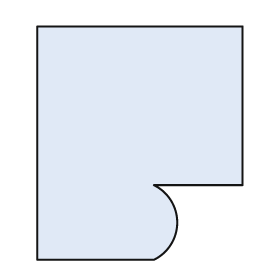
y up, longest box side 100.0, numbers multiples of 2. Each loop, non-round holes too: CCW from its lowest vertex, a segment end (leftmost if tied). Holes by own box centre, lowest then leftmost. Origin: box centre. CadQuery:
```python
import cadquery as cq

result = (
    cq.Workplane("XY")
    .moveTo(-44.0, -50.0)
    .lineTo(6.0, -50.0)
    .threePointArc((16.0, -34.0), (6.0, -18.0))
    .lineTo(44.0, -18.0)
    .lineTo(44.0, 50.0)
    .lineTo(-44.0, 50.0)
    .close()
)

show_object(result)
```